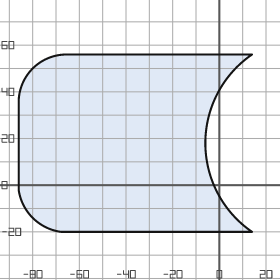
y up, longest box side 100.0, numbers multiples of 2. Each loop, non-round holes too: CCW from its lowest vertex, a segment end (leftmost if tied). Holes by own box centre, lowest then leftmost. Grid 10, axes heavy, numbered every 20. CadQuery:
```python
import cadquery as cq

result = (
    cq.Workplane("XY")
    .moveTo(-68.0, -20.0)
    .lineTo(14.0, -20.0)
    .threePointArc((-6.0, 18.0), (14.0, 56.0))
    .lineTo(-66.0, 56.0)
    .threePointArc((-80.0, 50.0), (-86.0, 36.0))
    .lineTo(-86.0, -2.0)
    .threePointArc((-80.0, -14.0), (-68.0, -20.0))
    .close()
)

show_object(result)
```